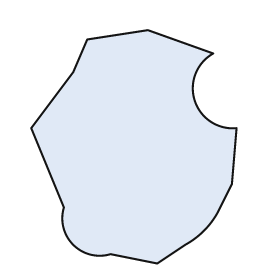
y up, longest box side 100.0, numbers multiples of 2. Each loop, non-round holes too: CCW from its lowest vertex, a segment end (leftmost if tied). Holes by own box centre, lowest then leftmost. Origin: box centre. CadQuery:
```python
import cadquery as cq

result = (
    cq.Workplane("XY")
    .moveTo(10.0, -50.0)
    .lineTo(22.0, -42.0)
    .threePointArc((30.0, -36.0), (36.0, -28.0))
    .lineTo(42.0, -16.0)
    .lineTo(44.0, 8.0)
    .threePointArc((26.0, 20.0), (34.0, 40.0))
    .lineTo(6.0, 50.0)
    .lineTo(-20.0, 46.0)
    .lineTo(-26.0, 32.0)
    .lineTo(-44.0, 8.0)
    .lineTo(-30.0, -26.0)
    .threePointArc((-26.0, -42.0), (-10.0, -46.0))
    .close()
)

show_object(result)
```